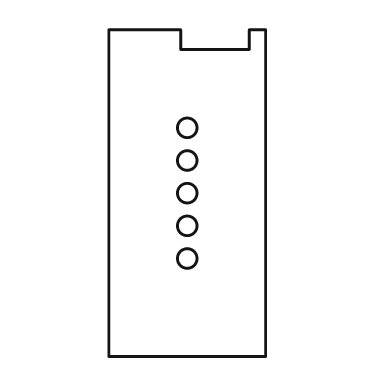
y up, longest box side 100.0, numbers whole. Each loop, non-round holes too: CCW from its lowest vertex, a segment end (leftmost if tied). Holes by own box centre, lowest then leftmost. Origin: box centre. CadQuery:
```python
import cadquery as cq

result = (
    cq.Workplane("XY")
    .moveTo(-24.0, -50.0)
    .lineTo(24.0, -50.0)
    .lineTo(24.0, 50.0)
    .lineTo(19.0, 50.0)
    .lineTo(19.0, 44.0)
    .lineTo(-2.0, 44.0)
    .lineTo(-2.0, 50.0)
    .lineTo(-24.0, 50.0)
    .close()
    .moveTo(0.0, -20.0)
    .circle(3.0)
    .moveTo(0.0, -10.0)
    .circle(3.0)
    .moveTo(0.0, 0.0)
    .circle(3.0)
    .moveTo(0.0, 10.0)
    .circle(3.0)
    .moveTo(0.0, 20.0)
    .circle(3.0)
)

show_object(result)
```